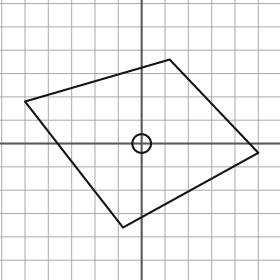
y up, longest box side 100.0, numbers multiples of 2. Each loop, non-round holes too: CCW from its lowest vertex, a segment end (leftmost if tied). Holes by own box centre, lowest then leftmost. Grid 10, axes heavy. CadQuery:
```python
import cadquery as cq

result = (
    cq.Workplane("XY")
    .moveTo(-8.0, -36.0)
    .lineTo(50.0, -4.0)
    .lineTo(12.0, 36.0)
    .lineTo(-50.0, 18.0)
    .close()
    .moveTo(0.0, 0.0)
    .circle(4.0)
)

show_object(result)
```